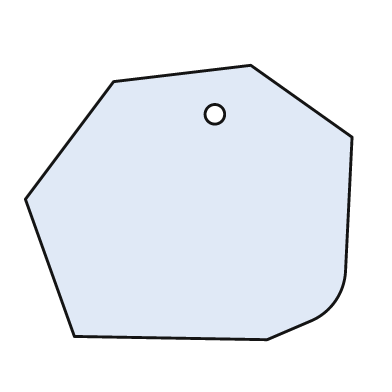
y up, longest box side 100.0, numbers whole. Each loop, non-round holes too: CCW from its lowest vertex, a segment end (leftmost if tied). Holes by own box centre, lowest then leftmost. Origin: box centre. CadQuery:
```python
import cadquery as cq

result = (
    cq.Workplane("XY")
    .moveTo(24.0, -42.0)
    .lineTo(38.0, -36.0)
    .threePointArc((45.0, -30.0), (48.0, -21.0))
    .lineTo(50.0, 20.0)
    .lineTo(19.0, 42.0)
    .lineTo(-23.0, 37.0)
    .lineTo(-50.0, 1.0)
    .lineTo(-35.0, -41.0)
    .close()
    .moveTo(8.0, 27.0)
    .circle(3.0)
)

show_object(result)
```